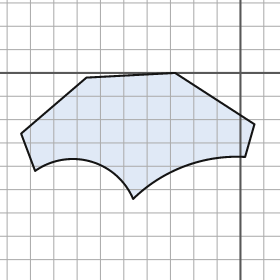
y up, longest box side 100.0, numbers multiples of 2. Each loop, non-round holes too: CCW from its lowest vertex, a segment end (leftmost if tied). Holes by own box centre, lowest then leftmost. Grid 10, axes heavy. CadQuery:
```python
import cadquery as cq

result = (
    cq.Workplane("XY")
    .moveTo(-46.0, -54.0)
    .threePointArc((-24.0, -40.0), (2.0, -36.0))
    .lineTo(6.0, -22.0)
    .lineTo(-28.0, 0.0)
    .lineTo(-66.0, -2.0)
    .lineTo(-94.0, -26.0)
    .lineTo(-88.0, -42.0)
    .threePointArc((-64.0, -38.0), (-46.0, -54.0))
    .close()
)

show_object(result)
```